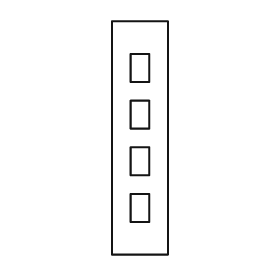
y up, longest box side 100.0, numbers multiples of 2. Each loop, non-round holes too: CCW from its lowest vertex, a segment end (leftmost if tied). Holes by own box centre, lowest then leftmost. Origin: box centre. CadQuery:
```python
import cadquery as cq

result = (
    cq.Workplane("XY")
    .moveTo(-12.0, -50.0)
    .lineTo(12.0, -50.0)
    .lineTo(12.0, 50.0)
    .lineTo(-12.0, 50.0)
    .close()
    .moveTo(-4.0, -36.0)
    .lineTo(4.0, -36.0)
    .lineTo(4.0, -24.0)
    .lineTo(-4.0, -24.0)
    .close()
    .moveTo(-4.0, -16.0)
    .lineTo(4.0, -16.0)
    .lineTo(4.0, -4.0)
    .lineTo(-4.0, -4.0)
    .close()
    .moveTo(-4.0, 4.0)
    .lineTo(4.0, 4.0)
    .lineTo(4.0, 16.0)
    .lineTo(-4.0, 16.0)
    .close()
    .moveTo(-4.0, 24.0)
    .lineTo(4.0, 24.0)
    .lineTo(4.0, 36.0)
    .lineTo(-4.0, 36.0)
    .close()
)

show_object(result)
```